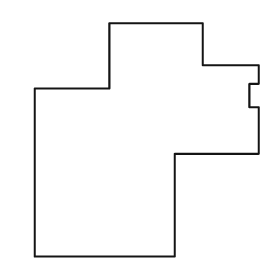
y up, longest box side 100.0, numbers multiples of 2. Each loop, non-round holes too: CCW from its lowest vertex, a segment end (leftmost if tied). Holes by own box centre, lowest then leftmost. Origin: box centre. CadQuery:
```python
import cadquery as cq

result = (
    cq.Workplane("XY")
    .moveTo(-48.0, -50.0)
    .lineTo(12.0, -50.0)
    .lineTo(12.0, -6.0)
    .lineTo(48.0, -6.0)
    .lineTo(48.0, 14.0)
    .lineTo(44.0, 14.0)
    .lineTo(44.0, 24.0)
    .lineTo(48.0, 24.0)
    .lineTo(48.0, 32.0)
    .lineTo(24.0, 32.0)
    .lineTo(24.0, 50.0)
    .lineTo(-16.0, 50.0)
    .lineTo(-16.0, 22.0)
    .lineTo(-48.0, 22.0)
    .close()
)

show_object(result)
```